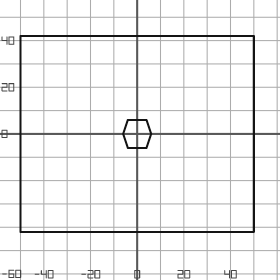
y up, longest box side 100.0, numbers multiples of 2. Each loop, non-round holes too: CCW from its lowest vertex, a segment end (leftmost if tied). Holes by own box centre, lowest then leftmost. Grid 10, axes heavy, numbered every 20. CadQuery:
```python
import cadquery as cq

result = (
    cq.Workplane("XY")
    .moveTo(-50.0, -42.0)
    .lineTo(50.0, -42.0)
    .lineTo(50.0, 42.0)
    .lineTo(-50.0, 42.0)
    .close()
    .moveTo(-4.0, -6.0)
    .lineTo(4.0, -6.0)
    .lineTo(6.0, 0.0)
    .lineTo(4.0, 6.0)
    .lineTo(-4.0, 6.0)
    .lineTo(-6.0, 0.0)
    .close()
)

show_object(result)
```